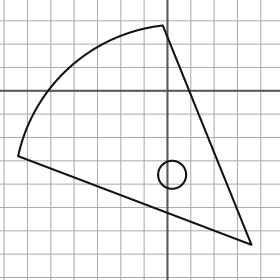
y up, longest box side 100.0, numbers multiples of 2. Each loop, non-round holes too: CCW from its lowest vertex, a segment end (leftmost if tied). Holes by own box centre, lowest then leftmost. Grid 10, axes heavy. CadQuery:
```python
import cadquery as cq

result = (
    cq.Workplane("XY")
    .moveTo(36.0, -66.0)
    .lineTo(-2.0, 28.0)
    .threePointArc((-42.0, 10.0), (-64.0, -28.0))
    .close()
    .moveTo(2.0, -36.0)
    .circle(6.0)
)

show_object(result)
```